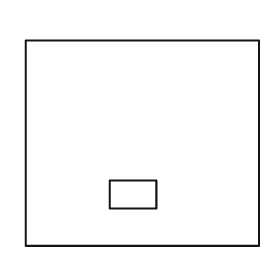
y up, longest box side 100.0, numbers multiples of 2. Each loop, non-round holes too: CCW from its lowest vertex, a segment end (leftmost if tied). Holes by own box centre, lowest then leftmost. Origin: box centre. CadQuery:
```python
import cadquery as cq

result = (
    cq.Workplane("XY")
    .moveTo(-50.0, -44.0)
    .lineTo(50.0, -44.0)
    .lineTo(50.0, 44.0)
    .lineTo(-50.0, 44.0)
    .close()
    .moveTo(-14.0, -28.0)
    .lineTo(6.0, -28.0)
    .lineTo(6.0, -16.0)
    .lineTo(-14.0, -16.0)
    .close()
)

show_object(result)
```